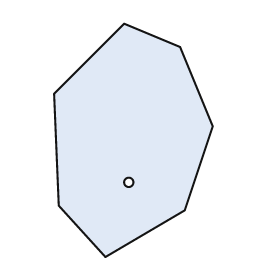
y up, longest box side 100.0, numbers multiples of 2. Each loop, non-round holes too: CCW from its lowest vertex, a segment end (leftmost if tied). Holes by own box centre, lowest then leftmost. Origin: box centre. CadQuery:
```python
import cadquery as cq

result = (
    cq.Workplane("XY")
    .moveTo(-12.0, -50.0)
    .lineTo(22.0, -30.0)
    .lineTo(34.0, 6.0)
    .lineTo(20.0, 40.0)
    .lineTo(-4.0, 50.0)
    .lineTo(-34.0, 20.0)
    .lineTo(-32.0, -28.0)
    .close()
    .moveTo(-2.0, -18.0)
    .circle(2.0)
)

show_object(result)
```